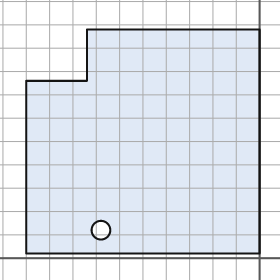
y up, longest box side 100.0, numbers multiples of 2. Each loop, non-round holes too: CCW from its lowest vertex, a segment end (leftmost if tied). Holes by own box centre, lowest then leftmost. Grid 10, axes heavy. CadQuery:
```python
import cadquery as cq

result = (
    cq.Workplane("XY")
    .moveTo(-100.0, 2.0)
    .lineTo(0.0, 2.0)
    .lineTo(0.0, 98.0)
    .lineTo(-74.0, 98.0)
    .lineTo(-74.0, 76.0)
    .lineTo(-100.0, 76.0)
    .close()
    .moveTo(-68.0, 12.0)
    .circle(4.0)
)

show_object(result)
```